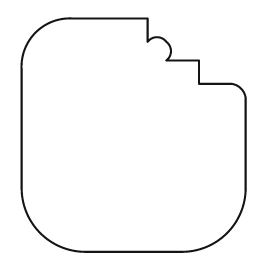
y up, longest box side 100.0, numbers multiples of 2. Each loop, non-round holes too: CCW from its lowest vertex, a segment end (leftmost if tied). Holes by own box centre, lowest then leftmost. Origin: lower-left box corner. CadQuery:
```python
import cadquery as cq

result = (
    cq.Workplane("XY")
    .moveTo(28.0, 0.0)
    .lineTo(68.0, 0.0)
    .threePointArc((88.0, 8.0), (96.0, 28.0))
    .lineTo(96.0, 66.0)
    .threePointArc((94.0, 70.0), (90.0, 72.0))
    .lineTo(76.0, 72.0)
    .lineTo(76.0, 82.0)
    .lineTo(62.0, 82.0)
    .threePointArc((64.0, 86.0), (62.0, 90.0))
    .threePointArc((58.0, 92.0), (54.0, 90.0))
    .lineTo(54.0, 100.0)
    .lineTo(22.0, 100.0)
    .threePointArc((6.0, 94.0), (0.0, 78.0))
    .lineTo(0.0, 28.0)
    .threePointArc((8.0, 8.0), (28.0, 0.0))
    .close()
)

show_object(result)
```